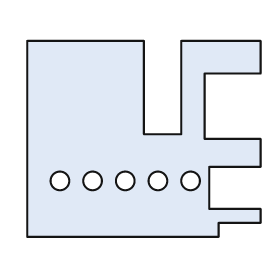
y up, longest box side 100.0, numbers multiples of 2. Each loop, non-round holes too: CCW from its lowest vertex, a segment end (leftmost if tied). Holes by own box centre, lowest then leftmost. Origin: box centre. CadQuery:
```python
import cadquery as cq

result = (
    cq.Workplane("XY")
    .moveTo(-50.0, -42.0)
    .lineTo(32.0, -42.0)
    .lineTo(32.0, -36.0)
    .lineTo(50.0, -36.0)
    .lineTo(50.0, -30.0)
    .lineTo(28.0, -30.0)
    .lineTo(28.0, -12.0)
    .lineTo(50.0, -12.0)
    .lineTo(50.0, 0.0)
    .lineTo(26.0, 0.0)
    .lineTo(26.0, 28.0)
    .lineTo(50.0, 28.0)
    .lineTo(50.0, 42.0)
    .lineTo(16.0, 42.0)
    .lineTo(16.0, 2.0)
    .lineTo(0.0, 2.0)
    .lineTo(0.0, 42.0)
    .lineTo(-50.0, 42.0)
    .close()
    .moveTo(-36.0, -18.0)
    .circle(4.0)
    .moveTo(-22.0, -18.0)
    .circle(4.0)
    .moveTo(-8.0, -18.0)
    .circle(4.0)
    .moveTo(6.0, -18.0)
    .circle(4.0)
    .moveTo(20.0, -18.0)
    .circle(4.0)
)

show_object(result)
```